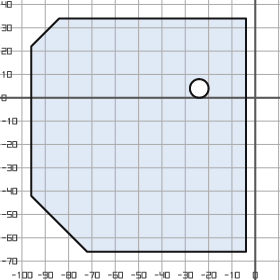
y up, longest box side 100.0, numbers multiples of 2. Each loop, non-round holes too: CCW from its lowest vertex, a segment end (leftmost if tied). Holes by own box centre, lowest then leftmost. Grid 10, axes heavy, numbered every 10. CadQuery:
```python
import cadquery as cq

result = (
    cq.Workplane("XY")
    .moveTo(-72.0, -66.0)
    .lineTo(-4.0, -66.0)
    .lineTo(-4.0, 34.0)
    .lineTo(-84.0, 34.0)
    .lineTo(-96.0, 22.0)
    .lineTo(-96.0, -42.0)
    .close()
    .moveTo(-24.0, 4.0)
    .circle(4.0)
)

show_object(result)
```